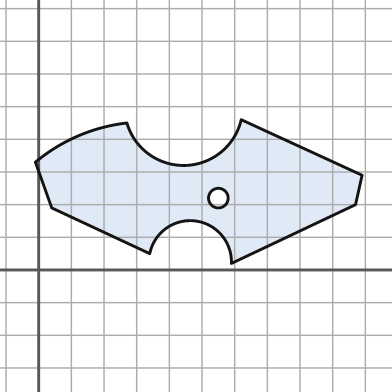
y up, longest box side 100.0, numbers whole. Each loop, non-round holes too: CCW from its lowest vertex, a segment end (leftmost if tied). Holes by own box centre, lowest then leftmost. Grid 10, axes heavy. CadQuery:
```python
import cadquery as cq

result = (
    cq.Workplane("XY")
    .moveTo(59.0, 2.0)
    .lineTo(97.0, 20.0)
    .lineTo(99.0, 29.0)
    .lineTo(62.0, 46.0)
    .threePointArc((45.0, 32.0), (27.0, 45.0))
    .threePointArc((12.0, 41.0), (-1.0, 33.0))
    .lineTo(4.0, 19.0)
    .lineTo(34.0, 5.0)
    .threePointArc((48.0, 15.0), (59.0, 2.0))
    .close()
    .moveTo(55.0, 22.0)
    .circle(3.0)
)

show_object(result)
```